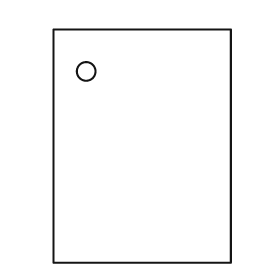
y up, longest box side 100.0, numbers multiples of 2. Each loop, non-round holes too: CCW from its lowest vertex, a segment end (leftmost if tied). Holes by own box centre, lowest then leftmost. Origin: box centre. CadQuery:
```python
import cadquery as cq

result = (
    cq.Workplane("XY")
    .moveTo(-38.0, -50.0)
    .lineTo(38.0, -50.0)
    .lineTo(38.0, 50.0)
    .lineTo(-38.0, 50.0)
    .close()
    .moveTo(-24.0, 32.0)
    .circle(4.0)
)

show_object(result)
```